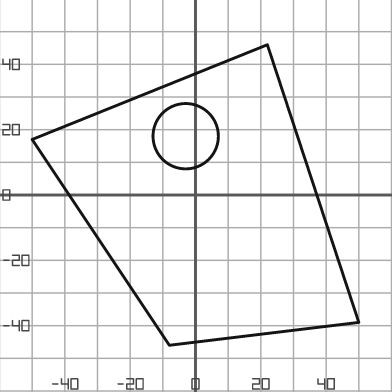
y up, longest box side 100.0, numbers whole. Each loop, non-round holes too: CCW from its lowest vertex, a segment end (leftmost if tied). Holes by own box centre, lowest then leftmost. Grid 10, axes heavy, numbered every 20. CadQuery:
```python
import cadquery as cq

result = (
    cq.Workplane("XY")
    .moveTo(-8.0, -46.0)
    .lineTo(50.0, -39.0)
    .lineTo(22.0, 46.0)
    .lineTo(-50.0, 17.0)
    .close()
    .moveTo(-3.0, 18.0)
    .circle(10.0)
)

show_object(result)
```